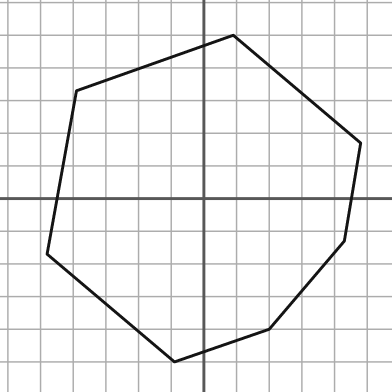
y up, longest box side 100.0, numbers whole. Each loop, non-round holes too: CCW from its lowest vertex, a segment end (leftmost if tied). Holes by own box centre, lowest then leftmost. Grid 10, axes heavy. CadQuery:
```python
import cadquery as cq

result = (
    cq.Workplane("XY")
    .moveTo(-9.0, -50.0)
    .lineTo(20.0, -40.0)
    .lineTo(43.0, -13.0)
    .lineTo(48.0, 17.0)
    .lineTo(9.0, 50.0)
    .lineTo(-39.0, 33.0)
    .lineTo(-48.0, -17.0)
    .close()
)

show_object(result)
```